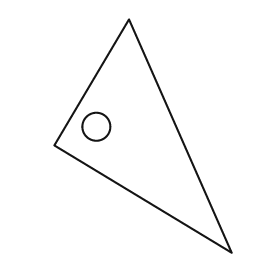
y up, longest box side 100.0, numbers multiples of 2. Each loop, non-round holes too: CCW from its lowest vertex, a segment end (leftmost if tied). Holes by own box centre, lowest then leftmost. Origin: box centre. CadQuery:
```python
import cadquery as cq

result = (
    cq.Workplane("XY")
    .moveTo(38.0, -50.0)
    .lineTo(-6.0, 50.0)
    .lineTo(-38.0, -4.0)
    .close()
    .moveTo(-20.0, 4.0)
    .circle(6.0)
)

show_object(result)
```